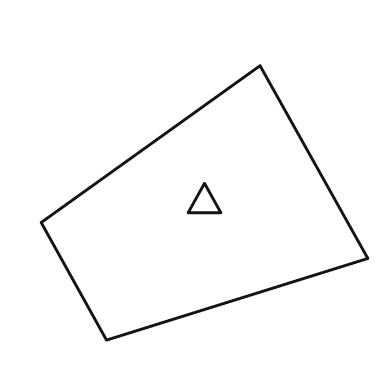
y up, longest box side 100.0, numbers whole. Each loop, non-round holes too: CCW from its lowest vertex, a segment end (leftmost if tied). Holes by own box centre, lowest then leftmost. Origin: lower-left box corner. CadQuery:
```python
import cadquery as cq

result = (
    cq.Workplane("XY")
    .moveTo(20.0, 0.0)
    .lineTo(100.0, 25.0)
    .lineTo(67.0, 84.0)
    .lineTo(0.0, 36.0)
    .close()
    .moveTo(45.0, 39.0)
    .lineTo(55.0, 39.0)
    .lineTo(50.0, 48.0)
    .close()
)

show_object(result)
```